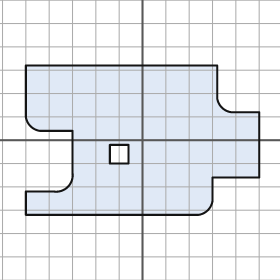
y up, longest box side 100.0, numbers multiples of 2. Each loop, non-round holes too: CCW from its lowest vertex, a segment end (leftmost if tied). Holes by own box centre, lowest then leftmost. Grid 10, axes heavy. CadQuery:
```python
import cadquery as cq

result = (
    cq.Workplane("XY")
    .moveTo(-50.0, -32.0)
    .lineTo(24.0, -32.0)
    .threePointArc((28.0, -30.0), (30.0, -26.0))
    .lineTo(30.0, -16.0)
    .lineTo(50.0, -16.0)
    .lineTo(50.0, 12.0)
    .lineTo(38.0, 12.0)
    .threePointArc((34.0, 14.0), (32.0, 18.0))
    .lineTo(32.0, 32.0)
    .lineTo(-50.0, 32.0)
    .lineTo(-50.0, 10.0)
    .threePointArc((-48.0, 6.0), (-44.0, 4.0))
    .lineTo(-30.0, 4.0)
    .lineTo(-30.0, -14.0)
    .threePointArc((-32.0, -20.0), (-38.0, -22.0))
    .lineTo(-50.0, -22.0)
    .close()
    .moveTo(-14.0, -10.0)
    .lineTo(-6.0, -10.0)
    .lineTo(-6.0, -2.0)
    .lineTo(-14.0, -2.0)
    .close()
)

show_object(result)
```